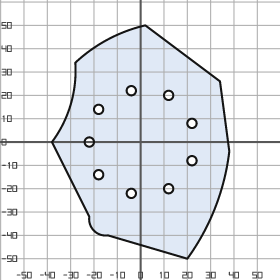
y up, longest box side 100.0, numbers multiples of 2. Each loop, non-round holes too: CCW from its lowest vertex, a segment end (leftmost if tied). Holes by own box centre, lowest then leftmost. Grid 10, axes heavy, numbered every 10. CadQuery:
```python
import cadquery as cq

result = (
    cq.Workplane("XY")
    .moveTo(20.0, -50.0)
    .threePointArc((32.0, -28.0), (38.0, -4.0))
    .lineTo(34.0, 26.0)
    .lineTo(2.0, 50.0)
    .threePointArc((-14.0, 44.0), (-28.0, 34.0))
    .threePointArc((-30.0, 16.0), (-38.0, 0.0))
    .lineTo(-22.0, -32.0)
    .threePointArc((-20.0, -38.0), (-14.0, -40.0))
    .close()
    .moveTo(-4.0, -22.0)
    .circle(2.0)
    .moveTo(12.0, -20.0)
    .circle(2.0)
    .moveTo(-18.0, -14.0)
    .circle(2.0)
    .moveTo(22.0, -8.0)
    .circle(2.0)
    .moveTo(-22.0, 0.0)
    .circle(2.0)
    .moveTo(22.0, 8.0)
    .circle(2.0)
    .moveTo(-18.0, 14.0)
    .circle(2.0)
    .moveTo(12.0, 20.0)
    .circle(2.0)
    .moveTo(-4.0, 22.0)
    .circle(2.0)
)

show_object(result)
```